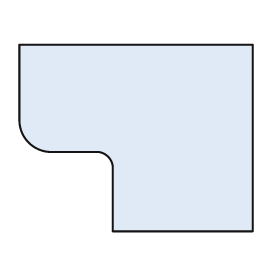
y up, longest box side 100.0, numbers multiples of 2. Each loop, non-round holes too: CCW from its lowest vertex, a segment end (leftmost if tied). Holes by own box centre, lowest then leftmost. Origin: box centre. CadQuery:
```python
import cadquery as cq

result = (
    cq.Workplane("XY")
    .moveTo(-10.0, -40.0)
    .lineTo(50.0, -40.0)
    .lineTo(50.0, 40.0)
    .lineTo(-50.0, 40.0)
    .lineTo(-50.0, 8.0)
    .threePointArc((-46.0, -2.0), (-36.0, -6.0))
    .lineTo(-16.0, -6.0)
    .threePointArc((-12.0, -8.0), (-10.0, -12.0))
    .close()
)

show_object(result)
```